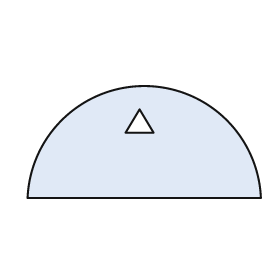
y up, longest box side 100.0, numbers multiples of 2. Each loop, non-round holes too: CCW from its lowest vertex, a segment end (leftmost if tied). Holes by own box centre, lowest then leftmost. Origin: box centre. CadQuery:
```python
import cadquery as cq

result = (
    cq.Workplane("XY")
    .moveTo(-50.0, -24.0)
    .lineTo(50.0, -24.0)
    .threePointArc((0.0, 24.0), (-50.0, -24.0))
    .close()
    .moveTo(-8.0, 4.0)
    .lineTo(4.0, 4.0)
    .lineTo(-2.0, 14.0)
    .close()
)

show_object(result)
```